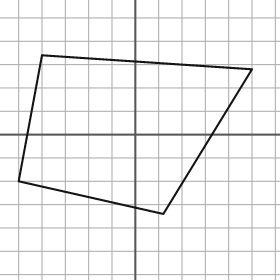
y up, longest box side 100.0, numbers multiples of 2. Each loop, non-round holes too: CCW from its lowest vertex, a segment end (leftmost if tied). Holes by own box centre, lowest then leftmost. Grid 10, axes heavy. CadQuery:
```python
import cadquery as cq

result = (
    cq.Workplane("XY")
    .moveTo(12.0, -34.0)
    .lineTo(50.0, 28.0)
    .lineTo(-40.0, 34.0)
    .lineTo(-50.0, -20.0)
    .close()
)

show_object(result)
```